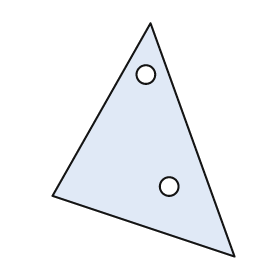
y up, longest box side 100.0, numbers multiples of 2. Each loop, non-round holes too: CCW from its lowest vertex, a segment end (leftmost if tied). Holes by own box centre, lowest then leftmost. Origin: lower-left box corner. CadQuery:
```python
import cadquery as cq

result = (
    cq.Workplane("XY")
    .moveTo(78.0, 0.0)
    .lineTo(42.0, 100.0)
    .lineTo(0.0, 26.0)
    .close()
    .moveTo(50.0, 30.0)
    .circle(4.0)
    .moveTo(40.0, 78.0)
    .circle(4.0)
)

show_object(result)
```